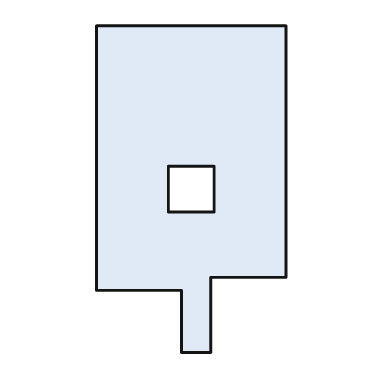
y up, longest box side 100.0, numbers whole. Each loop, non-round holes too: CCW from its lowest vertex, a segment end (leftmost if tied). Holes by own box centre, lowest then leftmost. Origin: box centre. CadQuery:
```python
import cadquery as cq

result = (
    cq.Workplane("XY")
    .moveTo(-3.0, -50.0)
    .lineTo(6.0, -50.0)
    .lineTo(6.0, -27.0)
    .lineTo(29.0, -27.0)
    .lineTo(29.0, 50.0)
    .lineTo(-29.0, 50.0)
    .lineTo(-29.0, -31.0)
    .lineTo(-3.0, -31.0)
    .close()
    .moveTo(-7.0, -7.0)
    .lineTo(7.0, -7.0)
    .lineTo(7.0, 7.0)
    .lineTo(-7.0, 7.0)
    .close()
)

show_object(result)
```